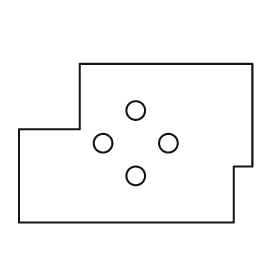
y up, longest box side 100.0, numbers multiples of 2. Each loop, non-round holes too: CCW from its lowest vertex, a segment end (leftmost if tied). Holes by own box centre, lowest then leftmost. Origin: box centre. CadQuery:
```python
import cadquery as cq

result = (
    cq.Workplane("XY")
    .moveTo(-50.0, -34.0)
    .lineTo(42.0, -34.0)
    .lineTo(42.0, -10.0)
    .lineTo(50.0, -10.0)
    .lineTo(50.0, 34.0)
    .lineTo(-24.0, 34.0)
    .lineTo(-24.0, 6.0)
    .lineTo(-50.0, 6.0)
    .close()
    .moveTo(0.0, -14.0)
    .circle(4.0)
    .moveTo(-14.0, 0.0)
    .circle(4.0)
    .moveTo(14.0, 0.0)
    .circle(4.0)
    .moveTo(0.0, 14.0)
    .circle(4.0)
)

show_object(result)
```